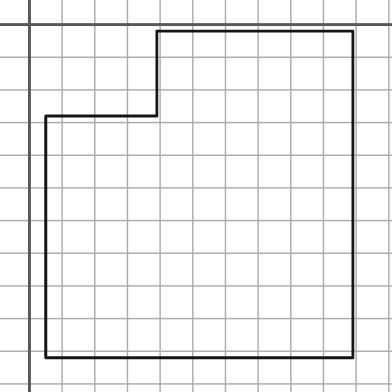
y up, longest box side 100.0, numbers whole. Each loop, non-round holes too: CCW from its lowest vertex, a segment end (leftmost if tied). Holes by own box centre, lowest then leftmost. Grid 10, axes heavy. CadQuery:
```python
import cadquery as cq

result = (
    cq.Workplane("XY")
    .moveTo(5.0, -102.0)
    .lineTo(99.0, -102.0)
    .lineTo(99.0, -2.0)
    .lineTo(39.0, -2.0)
    .lineTo(39.0, -28.0)
    .lineTo(5.0, -28.0)
    .close()
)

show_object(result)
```